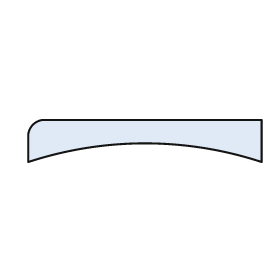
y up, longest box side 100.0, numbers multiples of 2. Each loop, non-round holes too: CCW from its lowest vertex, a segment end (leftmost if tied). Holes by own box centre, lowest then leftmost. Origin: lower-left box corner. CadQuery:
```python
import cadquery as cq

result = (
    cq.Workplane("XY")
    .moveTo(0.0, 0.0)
    .threePointArc((50.0, 8.0), (100.0, 0.0))
    .lineTo(100.0, 18.0)
    .lineTo(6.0, 18.0)
    .threePointArc((2.0, 16.0), (0.0, 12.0))
    .close()
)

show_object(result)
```